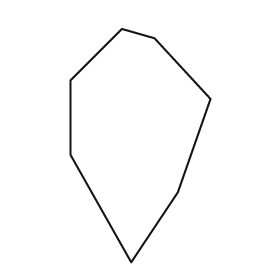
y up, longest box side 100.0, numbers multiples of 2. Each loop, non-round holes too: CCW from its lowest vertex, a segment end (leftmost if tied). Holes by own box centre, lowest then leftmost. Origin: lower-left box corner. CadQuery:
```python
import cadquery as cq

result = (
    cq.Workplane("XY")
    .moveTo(26.0, 0.0)
    .lineTo(46.0, 30.0)
    .lineTo(60.0, 70.0)
    .lineTo(36.0, 96.0)
    .lineTo(22.0, 100.0)
    .lineTo(0.0, 78.0)
    .lineTo(0.0, 46.0)
    .close()
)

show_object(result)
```